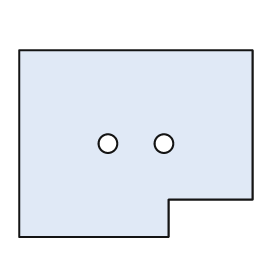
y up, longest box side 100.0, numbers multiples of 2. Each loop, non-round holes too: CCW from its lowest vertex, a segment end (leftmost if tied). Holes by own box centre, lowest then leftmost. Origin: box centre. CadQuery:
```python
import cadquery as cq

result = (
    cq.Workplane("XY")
    .moveTo(-50.0, -40.0)
    .lineTo(14.0, -40.0)
    .lineTo(14.0, -24.0)
    .lineTo(50.0, -24.0)
    .lineTo(50.0, 40.0)
    .lineTo(-50.0, 40.0)
    .close()
    .moveTo(-12.0, 0.0)
    .circle(4.0)
    .moveTo(12.0, 0.0)
    .circle(4.0)
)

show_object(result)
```